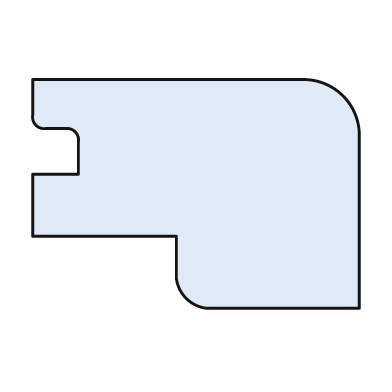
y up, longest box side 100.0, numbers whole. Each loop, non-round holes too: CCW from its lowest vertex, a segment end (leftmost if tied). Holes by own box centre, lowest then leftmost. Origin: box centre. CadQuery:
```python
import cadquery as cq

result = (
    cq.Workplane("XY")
    .moveTo(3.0, -35.0)
    .lineTo(50.0, -35.0)
    .lineTo(50.0, 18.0)
    .threePointArc((45.0, 30.0), (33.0, 35.0))
    .lineTo(-50.0, 35.0)
    .lineTo(-50.0, 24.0)
    .threePointArc((-49.0, 21.0), (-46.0, 20.0))
    .lineTo(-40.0, 20.0)
    .threePointArc((-37.0, 19.0), (-36.0, 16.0))
    .lineTo(-36.0, 6.0)
    .lineTo(-50.0, 6.0)
    .lineTo(-50.0, -13.0)
    .lineTo(-6.0, -13.0)
    .lineTo(-6.0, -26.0)
    .threePointArc((-3.0, -32.0), (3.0, -35.0))
    .close()
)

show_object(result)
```